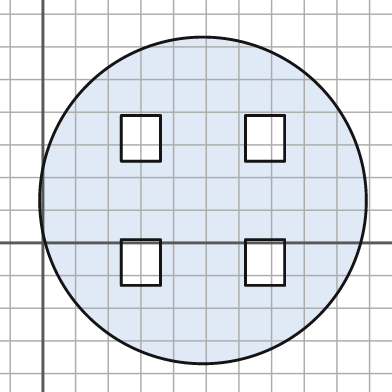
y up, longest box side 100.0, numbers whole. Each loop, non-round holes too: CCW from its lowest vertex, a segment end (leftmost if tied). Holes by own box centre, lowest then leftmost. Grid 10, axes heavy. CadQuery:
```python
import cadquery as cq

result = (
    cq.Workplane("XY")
    .moveTo(49.0, 13.0)
    .circle(50.0)
    .moveTo(24.0, -13.0)
    .lineTo(36.0, -13.0)
    .lineTo(36.0, 1.0)
    .lineTo(24.0, 1.0)
    .close()
    .moveTo(62.0, -13.0)
    .lineTo(74.0, -13.0)
    .lineTo(74.0, 1.0)
    .lineTo(62.0, 1.0)
    .close()
    .moveTo(24.0, 25.0)
    .lineTo(36.0, 25.0)
    .lineTo(36.0, 39.0)
    .lineTo(24.0, 39.0)
    .close()
    .moveTo(62.0, 25.0)
    .lineTo(74.0, 25.0)
    .lineTo(74.0, 39.0)
    .lineTo(62.0, 39.0)
    .close()
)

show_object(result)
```